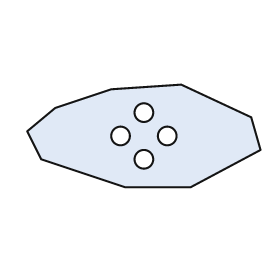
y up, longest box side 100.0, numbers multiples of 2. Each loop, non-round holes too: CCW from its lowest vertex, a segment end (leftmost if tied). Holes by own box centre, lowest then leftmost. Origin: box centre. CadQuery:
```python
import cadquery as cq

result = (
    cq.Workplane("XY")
    .moveTo(-8.0, -22.0)
    .lineTo(20.0, -22.0)
    .lineTo(50.0, -6.0)
    .lineTo(46.0, 8.0)
    .lineTo(16.0, 22.0)
    .lineTo(-14.0, 20.0)
    .lineTo(-38.0, 12.0)
    .lineTo(-50.0, 2.0)
    .lineTo(-44.0, -10.0)
    .close()
    .moveTo(0.0, -10.0)
    .circle(4.0)
    .moveTo(-10.0, 0.0)
    .circle(4.0)
    .moveTo(10.0, 0.0)
    .circle(4.0)
    .moveTo(0.0, 10.0)
    .circle(4.0)
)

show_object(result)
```